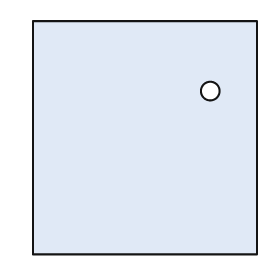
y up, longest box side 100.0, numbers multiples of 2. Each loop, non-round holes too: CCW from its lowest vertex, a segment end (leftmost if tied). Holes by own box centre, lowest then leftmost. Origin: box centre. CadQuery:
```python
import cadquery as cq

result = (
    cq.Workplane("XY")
    .moveTo(-48.0, -50.0)
    .lineTo(48.0, -50.0)
    .lineTo(48.0, 50.0)
    .lineTo(-48.0, 50.0)
    .close()
    .moveTo(28.0, 20.0)
    .circle(4.0)
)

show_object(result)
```